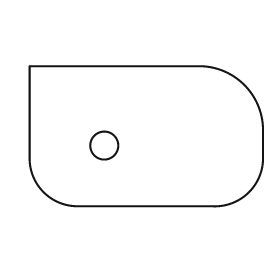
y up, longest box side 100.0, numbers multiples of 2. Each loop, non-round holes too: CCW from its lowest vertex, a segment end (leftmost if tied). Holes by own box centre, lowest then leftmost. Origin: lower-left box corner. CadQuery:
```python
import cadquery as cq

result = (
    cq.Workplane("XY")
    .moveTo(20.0, 0.0)
    .lineTo(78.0, 0.0)
    .threePointArc((94.0, 6.0), (100.0, 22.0))
    .lineTo(100.0, 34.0)
    .threePointArc((92.0, 52.0), (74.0, 60.0))
    .lineTo(0.0, 60.0)
    .lineTo(0.0, 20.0)
    .threePointArc((6.0, 6.0), (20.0, 0.0))
    .close()
    .moveTo(32.0, 26.0)
    .circle(6.0)
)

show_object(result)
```